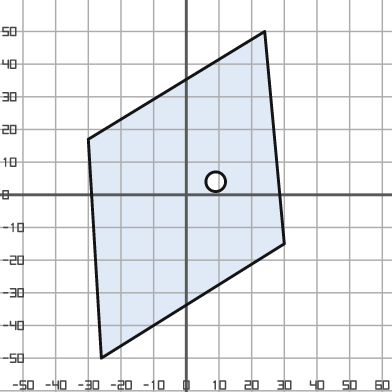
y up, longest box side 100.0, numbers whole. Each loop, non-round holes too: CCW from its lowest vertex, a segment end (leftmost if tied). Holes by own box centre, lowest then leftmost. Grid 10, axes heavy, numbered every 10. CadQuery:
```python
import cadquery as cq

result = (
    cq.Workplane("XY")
    .moveTo(-26.0, -50.0)
    .lineTo(30.0, -15.0)
    .lineTo(24.0, 50.0)
    .lineTo(-30.0, 17.0)
    .close()
    .moveTo(9.0, 4.0)
    .circle(3.0)
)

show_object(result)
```